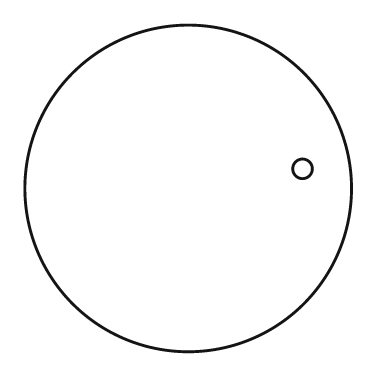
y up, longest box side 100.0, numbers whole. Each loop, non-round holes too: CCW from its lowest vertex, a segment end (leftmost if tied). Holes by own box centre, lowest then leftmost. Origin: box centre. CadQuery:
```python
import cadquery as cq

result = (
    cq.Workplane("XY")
    .moveTo(0.0, 0.0)
    .circle(50.0)
    .moveTo(35.0, 6.0)
    .circle(3.0)
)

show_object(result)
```